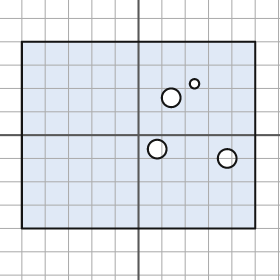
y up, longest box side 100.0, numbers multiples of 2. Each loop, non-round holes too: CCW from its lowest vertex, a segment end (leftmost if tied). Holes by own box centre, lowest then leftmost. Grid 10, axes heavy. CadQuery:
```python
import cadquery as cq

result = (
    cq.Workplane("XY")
    .moveTo(-50.0, -40.0)
    .lineTo(50.0, -40.0)
    .lineTo(50.0, 40.0)
    .lineTo(-50.0, 40.0)
    .close()
    .moveTo(38.0, -10.0)
    .circle(4.0)
    .moveTo(8.0, -6.0)
    .circle(4.0)
    .moveTo(14.0, 16.0)
    .circle(4.0)
    .moveTo(24.0, 22.0)
    .circle(2.0)
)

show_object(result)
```